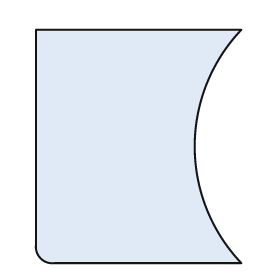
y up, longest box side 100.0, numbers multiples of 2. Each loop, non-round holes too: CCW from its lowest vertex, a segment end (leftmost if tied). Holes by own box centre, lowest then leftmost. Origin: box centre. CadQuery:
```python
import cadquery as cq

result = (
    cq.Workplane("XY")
    .moveTo(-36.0, -50.0)
    .lineTo(44.0, -50.0)
    .threePointArc((24.0, 0.0), (44.0, 50.0))
    .lineTo(-44.0, 50.0)
    .lineTo(-44.0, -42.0)
    .threePointArc((-42.0, -48.0), (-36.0, -50.0))
    .close()
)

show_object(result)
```